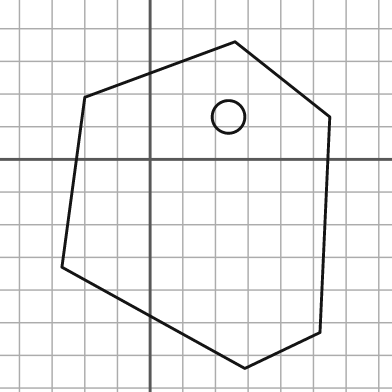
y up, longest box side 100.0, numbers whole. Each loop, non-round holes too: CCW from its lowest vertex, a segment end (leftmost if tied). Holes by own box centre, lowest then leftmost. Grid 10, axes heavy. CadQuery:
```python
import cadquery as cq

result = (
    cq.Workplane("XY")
    .moveTo(29.0, -64.0)
    .lineTo(52.0, -53.0)
    .lineTo(55.0, 13.0)
    .lineTo(26.0, 36.0)
    .lineTo(-20.0, 19.0)
    .lineTo(-27.0, -33.0)
    .close()
    .moveTo(24.0, 13.0)
    .circle(5.0)
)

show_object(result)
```